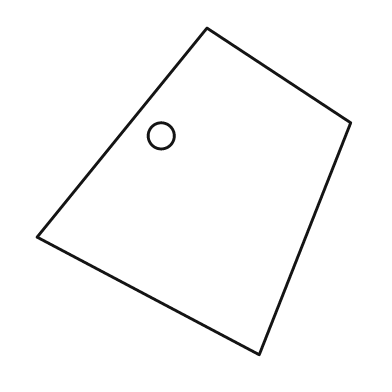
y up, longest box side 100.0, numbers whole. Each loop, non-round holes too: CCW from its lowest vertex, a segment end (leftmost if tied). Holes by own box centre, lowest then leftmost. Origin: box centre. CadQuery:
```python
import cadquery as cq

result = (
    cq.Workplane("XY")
    .moveTo(20.0, -50.0)
    .lineTo(48.0, 21.0)
    .lineTo(4.0, 50.0)
    .lineTo(-48.0, -14.0)
    .close()
    .moveTo(-10.0, 17.0)
    .circle(4.0)
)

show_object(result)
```